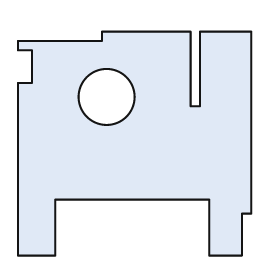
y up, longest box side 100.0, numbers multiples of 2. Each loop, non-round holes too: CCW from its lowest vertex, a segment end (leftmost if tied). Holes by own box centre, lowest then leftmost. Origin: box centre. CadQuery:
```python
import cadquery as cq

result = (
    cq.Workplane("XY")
    .moveTo(-50.0, -48.0)
    .lineTo(-34.0, -48.0)
    .lineTo(-34.0, -24.0)
    .lineTo(32.0, -24.0)
    .lineTo(32.0, -48.0)
    .lineTo(46.0, -48.0)
    .lineTo(46.0, -30.0)
    .lineTo(50.0, -30.0)
    .lineTo(50.0, 48.0)
    .lineTo(28.0, 48.0)
    .lineTo(28.0, 16.0)
    .lineTo(24.0, 16.0)
    .lineTo(24.0, 48.0)
    .lineTo(-14.0, 48.0)
    .lineTo(-14.0, 44.0)
    .lineTo(-50.0, 44.0)
    .lineTo(-50.0, 40.0)
    .lineTo(-44.0, 40.0)
    .lineTo(-44.0, 26.0)
    .lineTo(-50.0, 26.0)
    .close()
    .moveTo(-12.0, 20.0)
    .circle(12.0)
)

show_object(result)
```